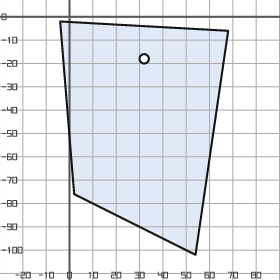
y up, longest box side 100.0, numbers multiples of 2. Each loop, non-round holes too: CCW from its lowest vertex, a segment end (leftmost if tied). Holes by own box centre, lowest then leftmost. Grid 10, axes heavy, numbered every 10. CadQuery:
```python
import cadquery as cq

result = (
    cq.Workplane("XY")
    .moveTo(54.0, -102.0)
    .lineTo(68.0, -6.0)
    .lineTo(-4.0, -2.0)
    .lineTo(2.0, -76.0)
    .close()
    .moveTo(32.0, -18.0)
    .circle(2.0)
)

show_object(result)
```